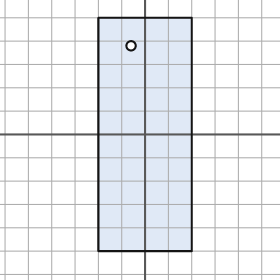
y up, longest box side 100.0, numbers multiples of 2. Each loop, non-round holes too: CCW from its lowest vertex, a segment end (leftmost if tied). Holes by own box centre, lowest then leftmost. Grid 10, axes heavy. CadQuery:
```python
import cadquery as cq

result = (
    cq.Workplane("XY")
    .moveTo(-20.0, -50.0)
    .lineTo(20.0, -50.0)
    .lineTo(20.0, 50.0)
    .lineTo(-20.0, 50.0)
    .close()
    .moveTo(-6.0, 38.0)
    .circle(2.0)
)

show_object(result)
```